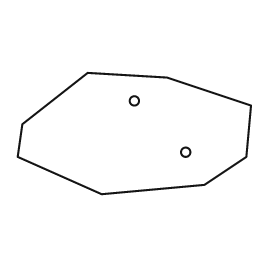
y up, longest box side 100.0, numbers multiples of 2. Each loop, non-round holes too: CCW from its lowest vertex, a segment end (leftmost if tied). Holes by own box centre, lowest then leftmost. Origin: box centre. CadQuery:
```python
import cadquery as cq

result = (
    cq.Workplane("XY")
    .moveTo(-14.0, -26.0)
    .lineTo(30.0, -22.0)
    .lineTo(48.0, -10.0)
    .lineTo(50.0, 12.0)
    .lineTo(14.0, 24.0)
    .lineTo(-20.0, 26.0)
    .lineTo(-48.0, 4.0)
    .lineTo(-50.0, -10.0)
    .close()
    .moveTo(22.0, -8.0)
    .circle(2.0)
    .moveTo(0.0, 14.0)
    .circle(2.0)
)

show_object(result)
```